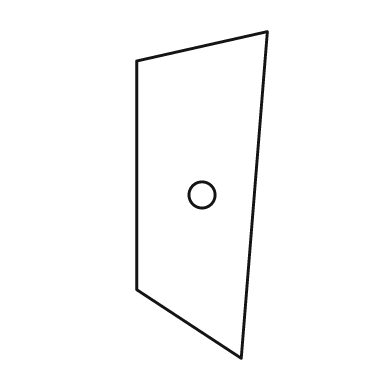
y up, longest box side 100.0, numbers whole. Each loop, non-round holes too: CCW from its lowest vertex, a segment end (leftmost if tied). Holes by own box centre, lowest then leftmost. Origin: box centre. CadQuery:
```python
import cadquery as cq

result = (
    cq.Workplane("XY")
    .moveTo(12.0, -50.0)
    .lineTo(20.0, 50.0)
    .lineTo(-20.0, 41.0)
    .lineTo(-20.0, -29.0)
    .close()
    .moveTo(0.0, 0.0)
    .circle(4.0)
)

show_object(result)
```